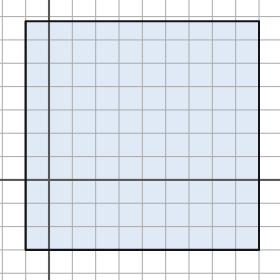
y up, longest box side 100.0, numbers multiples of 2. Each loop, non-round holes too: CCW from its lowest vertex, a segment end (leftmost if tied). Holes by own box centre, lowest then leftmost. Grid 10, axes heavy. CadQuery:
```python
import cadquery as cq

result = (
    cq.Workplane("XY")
    .moveTo(-10.0, -30.0)
    .lineTo(90.0, -30.0)
    .lineTo(90.0, 68.0)
    .lineTo(-10.0, 68.0)
    .close()
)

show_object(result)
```